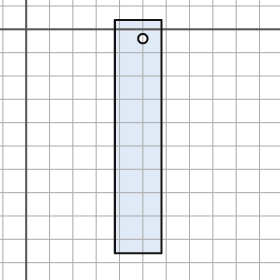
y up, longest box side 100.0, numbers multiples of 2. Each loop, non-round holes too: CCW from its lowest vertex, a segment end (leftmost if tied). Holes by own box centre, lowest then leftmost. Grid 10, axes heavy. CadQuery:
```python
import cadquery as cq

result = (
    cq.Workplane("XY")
    .moveTo(38.0, -96.0)
    .lineTo(58.0, -96.0)
    .lineTo(58.0, 4.0)
    .lineTo(38.0, 4.0)
    .close()
    .moveTo(50.0, -4.0)
    .circle(2.0)
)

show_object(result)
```